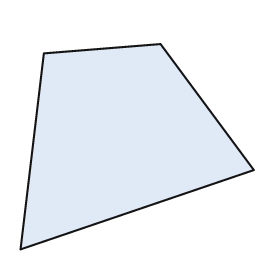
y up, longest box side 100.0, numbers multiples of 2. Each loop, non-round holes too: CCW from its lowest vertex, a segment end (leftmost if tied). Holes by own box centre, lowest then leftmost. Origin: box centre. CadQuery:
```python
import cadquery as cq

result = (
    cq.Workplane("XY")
    .moveTo(-50.0, -44.0)
    .lineTo(50.0, -10.0)
    .lineTo(10.0, 44.0)
    .lineTo(-40.0, 40.0)
    .close()
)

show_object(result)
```